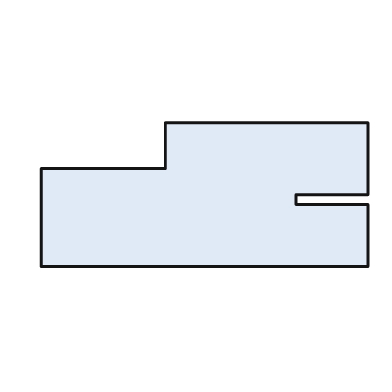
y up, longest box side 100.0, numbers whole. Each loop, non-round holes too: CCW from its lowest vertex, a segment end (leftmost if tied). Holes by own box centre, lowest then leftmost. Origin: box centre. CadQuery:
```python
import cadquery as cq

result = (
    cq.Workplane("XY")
    .moveTo(-50.0, -22.0)
    .lineTo(50.0, -22.0)
    .lineTo(50.0, -3.0)
    .lineTo(28.0, -3.0)
    .lineTo(28.0, 0.0)
    .lineTo(50.0, 0.0)
    .lineTo(50.0, 22.0)
    .lineTo(-12.0, 22.0)
    .lineTo(-12.0, 8.0)
    .lineTo(-50.0, 8.0)
    .close()
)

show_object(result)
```